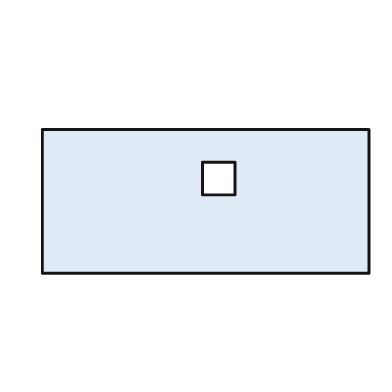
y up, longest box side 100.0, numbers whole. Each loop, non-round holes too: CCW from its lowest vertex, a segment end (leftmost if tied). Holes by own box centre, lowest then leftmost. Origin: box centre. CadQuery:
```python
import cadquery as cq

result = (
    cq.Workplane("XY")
    .moveTo(-50.0, -22.0)
    .lineTo(50.0, -22.0)
    .lineTo(50.0, 22.0)
    .lineTo(-50.0, 22.0)
    .close()
    .moveTo(-1.0, 2.0)
    .lineTo(9.0, 2.0)
    .lineTo(9.0, 12.0)
    .lineTo(-1.0, 12.0)
    .close()
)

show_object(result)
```